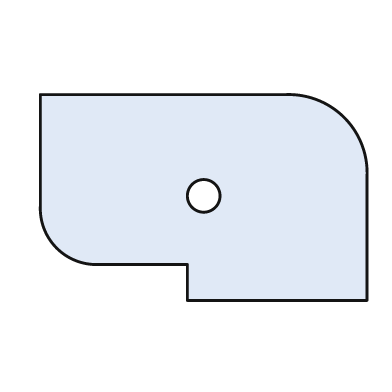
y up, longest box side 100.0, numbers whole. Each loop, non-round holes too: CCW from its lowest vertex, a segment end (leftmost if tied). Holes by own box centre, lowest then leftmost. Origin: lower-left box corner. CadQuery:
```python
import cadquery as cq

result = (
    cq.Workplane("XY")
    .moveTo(45.0, 0.0)
    .lineTo(100.0, 0.0)
    .lineTo(100.0, 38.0)
    .threePointArc((93.0, 56.0), (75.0, 63.0))
    .lineTo(0.0, 63.0)
    .lineTo(0.0, 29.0)
    .threePointArc((5.0, 16.0), (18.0, 11.0))
    .lineTo(45.0, 11.0)
    .close()
    .moveTo(50.0, 32.0)
    .circle(5.0)
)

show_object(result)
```